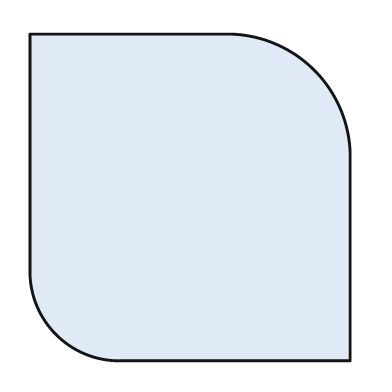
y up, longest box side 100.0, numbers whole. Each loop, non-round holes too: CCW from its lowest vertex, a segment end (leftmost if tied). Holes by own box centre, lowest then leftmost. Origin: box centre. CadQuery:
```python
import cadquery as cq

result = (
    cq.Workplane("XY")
    .moveTo(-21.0, -50.0)
    .lineTo(49.0, -50.0)
    .lineTo(49.0, 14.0)
    .threePointArc((38.0, 39.0), (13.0, 50.0))
    .lineTo(-49.0, 50.0)
    .lineTo(-49.0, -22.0)
    .threePointArc((-41.0, -42.0), (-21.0, -50.0))
    .close()
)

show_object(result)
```